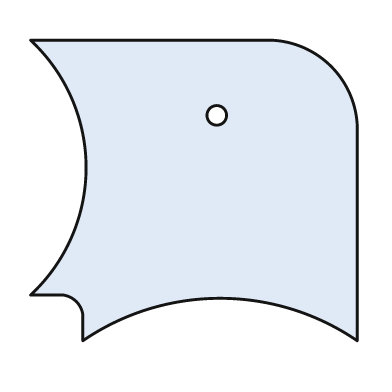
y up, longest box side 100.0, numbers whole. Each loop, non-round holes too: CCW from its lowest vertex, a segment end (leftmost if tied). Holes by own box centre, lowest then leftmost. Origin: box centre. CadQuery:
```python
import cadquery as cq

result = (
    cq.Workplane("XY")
    .moveTo(-34.0, -46.0)
    .threePointArc((8.0, -33.0), (50.0, -46.0))
    .lineTo(50.0, 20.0)
    .threePointArc((42.0, 38.0), (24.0, 46.0))
    .lineTo(-50.0, 46.0)
    .threePointArc((-33.0, 7.0), (-50.0, -32.0))
    .lineTo(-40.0, -32.0)
    .threePointArc((-36.0, -34.0), (-34.0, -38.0))
    .close()
    .moveTo(7.0, 23.0)
    .circle(3.0)
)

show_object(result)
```